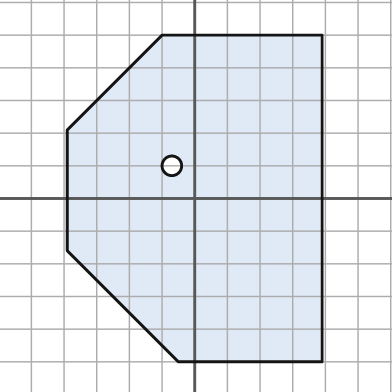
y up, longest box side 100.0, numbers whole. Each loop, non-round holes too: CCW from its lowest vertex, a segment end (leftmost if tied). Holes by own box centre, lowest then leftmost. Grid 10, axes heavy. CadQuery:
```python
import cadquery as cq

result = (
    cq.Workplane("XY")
    .moveTo(-5.0, -50.0)
    .lineTo(39.0, -50.0)
    .lineTo(39.0, 50.0)
    .lineTo(-10.0, 50.0)
    .lineTo(-39.0, 21.0)
    .lineTo(-39.0, -16.0)
    .close()
    .moveTo(-7.0, 10.0)
    .circle(3.0)
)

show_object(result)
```